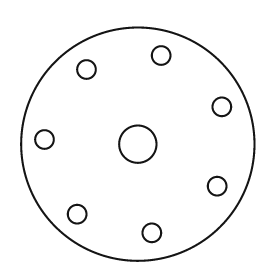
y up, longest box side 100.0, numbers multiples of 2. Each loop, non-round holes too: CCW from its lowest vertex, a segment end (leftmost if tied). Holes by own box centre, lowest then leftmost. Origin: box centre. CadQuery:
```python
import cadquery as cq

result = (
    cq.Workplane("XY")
    .moveTo(0.0, 0.0)
    .circle(50.0)
    .moveTo(6.0, -38.0)
    .circle(4.0)
    .moveTo(-26.0, -30.0)
    .circle(4.0)
    .moveTo(34.0, -18.0)
    .circle(4.0)
    .moveTo(0.0, 0.0)
    .circle(8.0)
    .moveTo(-40.0, 2.0)
    .circle(4.0)
    .moveTo(36.0, 16.0)
    .circle(4.0)
    .moveTo(-22.0, 32.0)
    .circle(4.0)
    .moveTo(10.0, 38.0)
    .circle(4.0)
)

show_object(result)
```